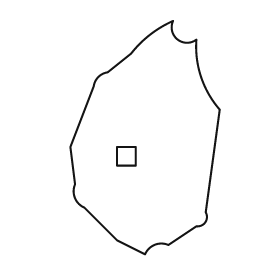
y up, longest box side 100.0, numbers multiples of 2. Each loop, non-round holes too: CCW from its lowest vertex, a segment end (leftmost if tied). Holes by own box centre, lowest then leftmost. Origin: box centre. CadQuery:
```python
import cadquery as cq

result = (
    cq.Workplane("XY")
    .moveTo(0.0, -50.0)
    .threePointArc((4.0, -46.0), (10.0, -46.0))
    .lineTo(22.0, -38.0)
    .threePointArc((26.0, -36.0), (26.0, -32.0))
    .lineTo(32.0, 12.0)
    .threePointArc((24.0, 26.0), (22.0, 42.0))
    .threePointArc((14.0, 42.0), (12.0, 50.0))
    .threePointArc((2.0, 44.0), (-6.0, 36.0))
    .lineTo(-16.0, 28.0)
    .threePointArc((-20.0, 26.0), (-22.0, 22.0))
    .lineTo(-32.0, -4.0)
    .lineTo(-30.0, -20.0)
    .threePointArc((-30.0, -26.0), (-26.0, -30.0))
    .lineTo(-12.0, -44.0)
    .close()
    .moveTo(-12.0, -12.0)
    .lineTo(-4.0, -12.0)
    .lineTo(-4.0, -4.0)
    .lineTo(-12.0, -4.0)
    .close()
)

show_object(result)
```